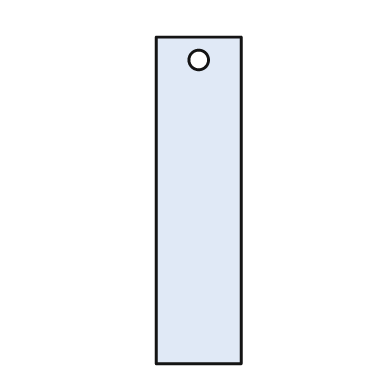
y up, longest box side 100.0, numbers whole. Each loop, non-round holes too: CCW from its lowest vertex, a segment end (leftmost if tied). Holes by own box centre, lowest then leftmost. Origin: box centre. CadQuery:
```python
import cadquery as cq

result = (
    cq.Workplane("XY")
    .moveTo(-13.0, -50.0)
    .lineTo(13.0, -50.0)
    .lineTo(13.0, 50.0)
    .lineTo(-13.0, 50.0)
    .close()
    .moveTo(0.0, 43.0)
    .circle(3.0)
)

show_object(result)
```